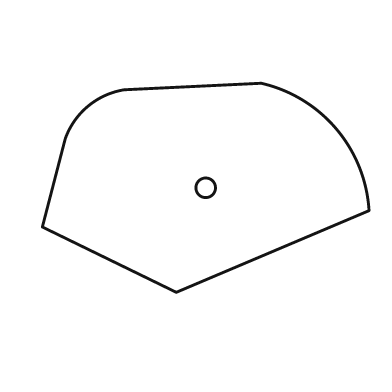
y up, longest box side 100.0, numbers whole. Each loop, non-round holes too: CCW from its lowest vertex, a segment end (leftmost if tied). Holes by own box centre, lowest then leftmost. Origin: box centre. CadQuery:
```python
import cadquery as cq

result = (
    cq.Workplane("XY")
    .moveTo(-9.0, -32.0)
    .lineTo(50.0, -7.0)
    .threePointArc((40.0, 18.0), (17.0, 32.0))
    .lineTo(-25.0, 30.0)
    .threePointArc((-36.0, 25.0), (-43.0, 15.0))
    .lineTo(-50.0, -12.0)
    .close()
    .moveTo(0.0, 0.0)
    .circle(3.0)
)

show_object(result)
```